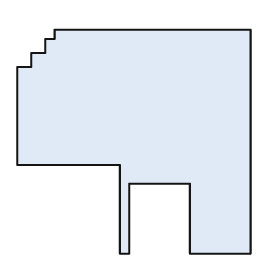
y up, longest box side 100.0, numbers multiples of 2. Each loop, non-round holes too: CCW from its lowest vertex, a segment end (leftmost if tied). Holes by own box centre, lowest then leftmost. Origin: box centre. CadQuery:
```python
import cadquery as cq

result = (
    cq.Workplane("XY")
    .moveTo(-6.0, -48.0)
    .lineTo(-2.0, -48.0)
    .lineTo(-2.0, -18.0)
    .lineTo(24.0, -18.0)
    .lineTo(24.0, -48.0)
    .lineTo(50.0, -48.0)
    .lineTo(50.0, 48.0)
    .lineTo(-34.0, 48.0)
    .lineTo(-34.0, 44.0)
    .lineTo(-38.0, 44.0)
    .lineTo(-38.0, 38.0)
    .lineTo(-44.0, 38.0)
    .lineTo(-44.0, 32.0)
    .lineTo(-50.0, 32.0)
    .lineTo(-50.0, -10.0)
    .lineTo(-6.0, -10.0)
    .close()
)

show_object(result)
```